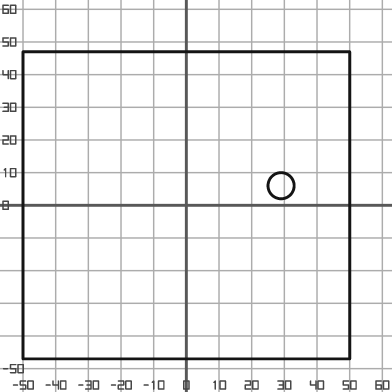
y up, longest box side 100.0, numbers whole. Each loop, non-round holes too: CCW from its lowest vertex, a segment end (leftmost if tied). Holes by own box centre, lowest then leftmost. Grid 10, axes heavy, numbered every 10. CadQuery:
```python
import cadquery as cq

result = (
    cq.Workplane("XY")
    .moveTo(-50.0, -47.0)
    .lineTo(50.0, -47.0)
    .lineTo(50.0, 47.0)
    .lineTo(-50.0, 47.0)
    .close()
    .moveTo(29.0, 6.0)
    .circle(4.0)
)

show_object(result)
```